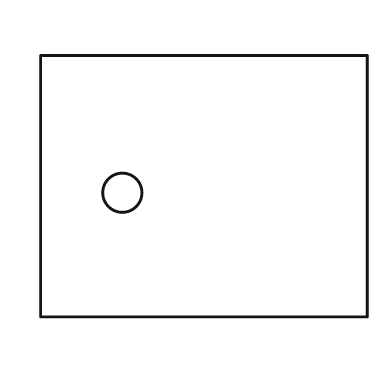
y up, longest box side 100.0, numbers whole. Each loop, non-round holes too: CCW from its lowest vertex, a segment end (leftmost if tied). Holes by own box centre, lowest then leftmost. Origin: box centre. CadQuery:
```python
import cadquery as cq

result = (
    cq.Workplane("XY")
    .moveTo(-50.0, -40.0)
    .lineTo(50.0, -40.0)
    .lineTo(50.0, 40.0)
    .lineTo(-50.0, 40.0)
    .close()
    .moveTo(-25.0, -2.0)
    .circle(6.0)
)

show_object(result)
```